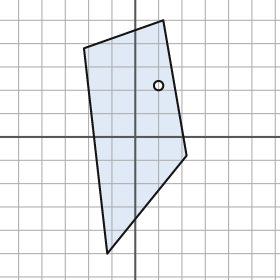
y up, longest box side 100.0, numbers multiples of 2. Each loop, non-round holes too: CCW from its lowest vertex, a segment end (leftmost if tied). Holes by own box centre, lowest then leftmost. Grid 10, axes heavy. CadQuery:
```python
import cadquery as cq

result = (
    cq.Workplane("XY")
    .moveTo(-12.0, -50.0)
    .lineTo(22.0, -8.0)
    .lineTo(12.0, 50.0)
    .lineTo(-22.0, 38.0)
    .close()
    .moveTo(10.0, 22.0)
    .circle(2.0)
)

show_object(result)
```